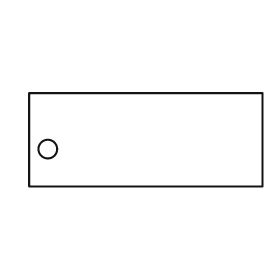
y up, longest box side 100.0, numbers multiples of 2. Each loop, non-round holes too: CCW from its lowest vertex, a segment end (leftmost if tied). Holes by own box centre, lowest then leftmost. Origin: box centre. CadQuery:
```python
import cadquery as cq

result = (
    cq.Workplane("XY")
    .moveTo(-50.0, -20.0)
    .lineTo(50.0, -20.0)
    .lineTo(50.0, 20.0)
    .lineTo(-50.0, 20.0)
    .close()
    .moveTo(-42.0, -4.0)
    .circle(4.0)
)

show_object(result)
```